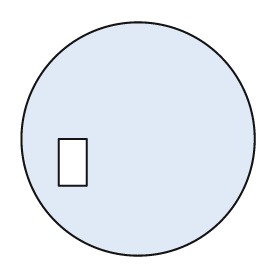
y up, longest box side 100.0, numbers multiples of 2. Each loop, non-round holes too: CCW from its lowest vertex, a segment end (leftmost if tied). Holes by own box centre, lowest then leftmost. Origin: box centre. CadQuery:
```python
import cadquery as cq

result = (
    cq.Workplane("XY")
    .moveTo(0.0, 0.0)
    .circle(50.0)
    .moveTo(-34.0, -20.0)
    .lineTo(-22.0, -20.0)
    .lineTo(-22.0, 0.0)
    .lineTo(-34.0, 0.0)
    .close()
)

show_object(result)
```